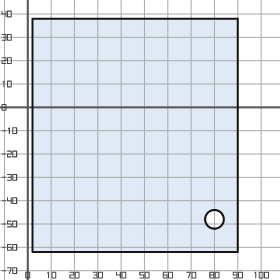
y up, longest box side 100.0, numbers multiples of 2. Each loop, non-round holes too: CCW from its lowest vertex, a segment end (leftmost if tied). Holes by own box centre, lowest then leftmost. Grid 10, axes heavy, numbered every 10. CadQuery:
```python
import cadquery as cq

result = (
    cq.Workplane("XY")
    .moveTo(2.0, -62.0)
    .lineTo(90.0, -62.0)
    .lineTo(90.0, 38.0)
    .lineTo(2.0, 38.0)
    .close()
    .moveTo(80.0, -48.0)
    .circle(4.0)
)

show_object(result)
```